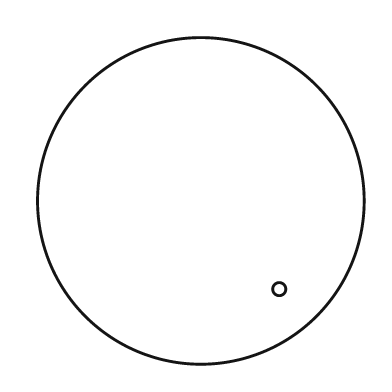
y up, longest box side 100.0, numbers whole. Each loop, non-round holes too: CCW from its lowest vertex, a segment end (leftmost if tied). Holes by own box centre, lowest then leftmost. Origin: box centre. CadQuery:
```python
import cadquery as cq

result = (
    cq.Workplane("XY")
    .moveTo(0.0, 0.0)
    .circle(50.0)
    .moveTo(24.0, -27.0)
    .circle(2.0)
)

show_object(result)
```